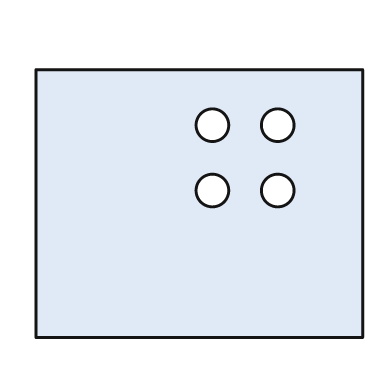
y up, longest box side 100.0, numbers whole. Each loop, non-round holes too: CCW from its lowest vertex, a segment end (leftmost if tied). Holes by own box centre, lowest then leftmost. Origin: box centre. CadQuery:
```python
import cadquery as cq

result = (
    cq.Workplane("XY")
    .moveTo(-50.0, -41.0)
    .lineTo(50.0, -41.0)
    .lineTo(50.0, 41.0)
    .lineTo(-50.0, 41.0)
    .close()
    .moveTo(4.0, 4.0)
    .circle(5.0)
    .moveTo(24.0, 4.0)
    .circle(5.0)
    .moveTo(4.0, 24.0)
    .circle(5.0)
    .moveTo(24.0, 24.0)
    .circle(5.0)
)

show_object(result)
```